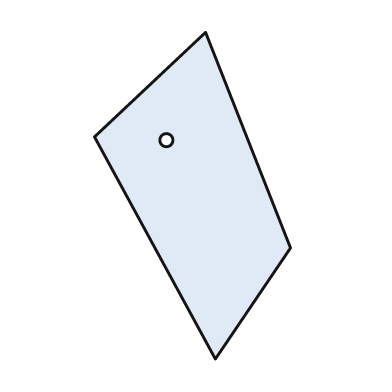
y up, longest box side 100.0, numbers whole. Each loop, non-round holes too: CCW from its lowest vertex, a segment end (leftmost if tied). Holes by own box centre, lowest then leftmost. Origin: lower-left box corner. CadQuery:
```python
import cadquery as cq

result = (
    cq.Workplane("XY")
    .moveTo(37.0, 0.0)
    .lineTo(60.0, 34.0)
    .lineTo(34.0, 100.0)
    .lineTo(0.0, 68.0)
    .close()
    .moveTo(22.0, 67.0)
    .circle(2.0)
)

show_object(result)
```